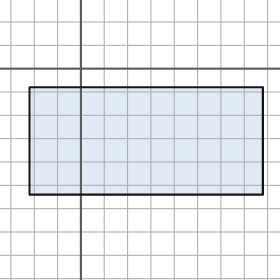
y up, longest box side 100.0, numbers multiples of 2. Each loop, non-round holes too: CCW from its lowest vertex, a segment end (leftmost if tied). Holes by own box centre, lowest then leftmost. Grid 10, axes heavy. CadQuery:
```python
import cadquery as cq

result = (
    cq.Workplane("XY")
    .moveTo(-22.0, -54.0)
    .lineTo(78.0, -54.0)
    .lineTo(78.0, -8.0)
    .lineTo(-22.0, -8.0)
    .close()
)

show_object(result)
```